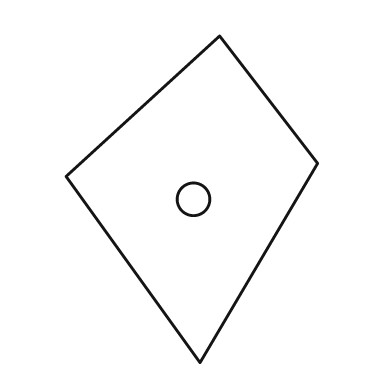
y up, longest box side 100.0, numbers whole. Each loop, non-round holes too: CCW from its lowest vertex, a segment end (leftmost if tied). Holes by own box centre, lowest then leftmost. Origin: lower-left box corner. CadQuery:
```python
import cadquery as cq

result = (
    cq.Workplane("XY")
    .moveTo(41.0, 0.0)
    .lineTo(77.0, 61.0)
    .lineTo(47.0, 100.0)
    .lineTo(0.0, 57.0)
    .close()
    .moveTo(39.0, 50.0)
    .circle(5.0)
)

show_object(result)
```